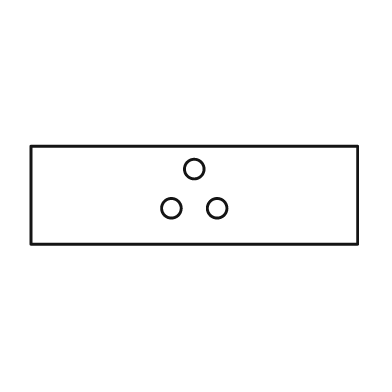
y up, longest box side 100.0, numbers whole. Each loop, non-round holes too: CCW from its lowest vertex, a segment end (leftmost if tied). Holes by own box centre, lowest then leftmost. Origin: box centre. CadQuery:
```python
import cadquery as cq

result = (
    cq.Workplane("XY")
    .moveTo(-50.0, -15.0)
    .lineTo(50.0, -15.0)
    .lineTo(50.0, 15.0)
    .lineTo(-50.0, 15.0)
    .close()
    .moveTo(-7.0, -4.0)
    .circle(3.0)
    .moveTo(7.0, -4.0)
    .circle(3.0)
    .moveTo(0.0, 8.0)
    .circle(3.0)
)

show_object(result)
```